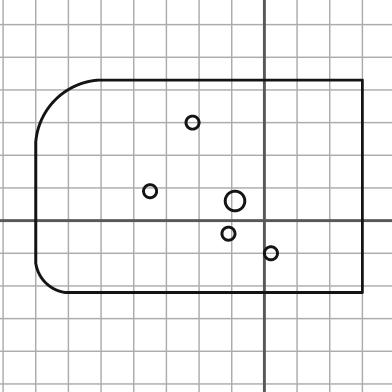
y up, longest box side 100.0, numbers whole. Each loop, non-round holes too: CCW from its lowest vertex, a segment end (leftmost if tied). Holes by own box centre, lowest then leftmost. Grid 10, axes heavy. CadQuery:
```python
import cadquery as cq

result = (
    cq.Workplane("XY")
    .moveTo(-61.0, -22.0)
    .lineTo(30.0, -22.0)
    .lineTo(30.0, 43.0)
    .lineTo(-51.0, 43.0)
    .threePointArc((-64.0, 37.0), (-70.0, 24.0))
    .lineTo(-70.0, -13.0)
    .threePointArc((-67.0, -19.0), (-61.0, -22.0))
    .close()
    .moveTo(2.0, -10.0)
    .circle(2.0)
    .moveTo(-11.0, -4.0)
    .circle(2.0)
    .moveTo(-9.0, 6.0)
    .circle(3.0)
    .moveTo(-35.0, 9.0)
    .circle(2.0)
    .moveTo(-22.0, 30.0)
    .circle(2.0)
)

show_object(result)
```